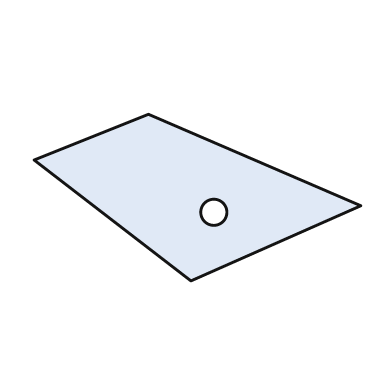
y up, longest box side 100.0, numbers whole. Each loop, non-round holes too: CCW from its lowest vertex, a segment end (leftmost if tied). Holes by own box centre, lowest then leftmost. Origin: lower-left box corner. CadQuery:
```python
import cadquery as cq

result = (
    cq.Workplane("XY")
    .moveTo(48.0, 0.0)
    .lineTo(100.0, 23.0)
    .lineTo(35.0, 51.0)
    .lineTo(0.0, 37.0)
    .close()
    .moveTo(55.0, 21.0)
    .circle(4.0)
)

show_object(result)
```